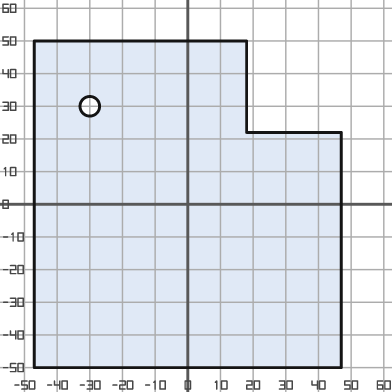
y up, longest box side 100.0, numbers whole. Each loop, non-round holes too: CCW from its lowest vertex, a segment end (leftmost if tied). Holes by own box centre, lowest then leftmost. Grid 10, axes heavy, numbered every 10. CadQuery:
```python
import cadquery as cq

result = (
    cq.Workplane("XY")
    .moveTo(-47.0, -50.0)
    .lineTo(47.0, -50.0)
    .lineTo(47.0, 22.0)
    .lineTo(18.0, 22.0)
    .lineTo(18.0, 50.0)
    .lineTo(-47.0, 50.0)
    .close()
    .moveTo(-30.0, 30.0)
    .circle(3.0)
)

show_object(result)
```